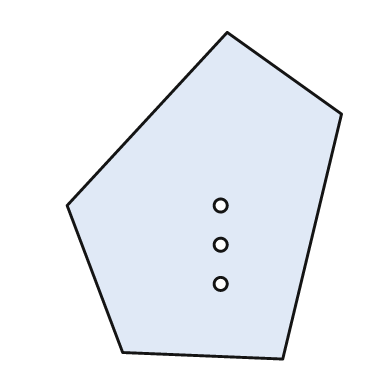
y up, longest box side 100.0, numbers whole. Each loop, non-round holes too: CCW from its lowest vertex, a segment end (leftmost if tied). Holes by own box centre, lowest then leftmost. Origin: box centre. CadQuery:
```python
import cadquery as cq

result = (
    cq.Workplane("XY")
    .moveTo(24.0, -50.0)
    .lineTo(42.0, 25.0)
    .lineTo(7.0, 50.0)
    .lineTo(-42.0, -3.0)
    .lineTo(-25.0, -48.0)
    .close()
    .moveTo(5.0, -27.0)
    .circle(2.0)
    .moveTo(5.0, -15.0)
    .circle(2.0)
    .moveTo(5.0, -3.0)
    .circle(2.0)
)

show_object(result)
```